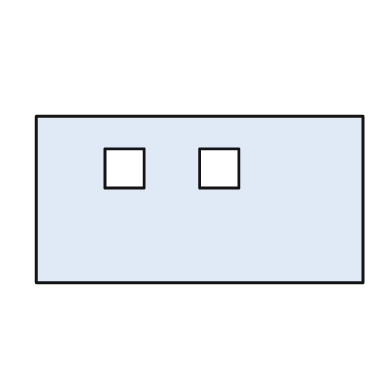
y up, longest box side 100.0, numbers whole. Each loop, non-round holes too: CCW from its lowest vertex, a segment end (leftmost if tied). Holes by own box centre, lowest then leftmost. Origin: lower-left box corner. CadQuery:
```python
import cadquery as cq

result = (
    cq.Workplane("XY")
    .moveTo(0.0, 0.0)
    .lineTo(100.0, 0.0)
    .lineTo(100.0, 51.0)
    .lineTo(0.0, 51.0)
    .close()
    .moveTo(21.0, 29.0)
    .lineTo(33.0, 29.0)
    .lineTo(33.0, 41.0)
    .lineTo(21.0, 41.0)
    .close()
    .moveTo(50.0, 29.0)
    .lineTo(62.0, 29.0)
    .lineTo(62.0, 41.0)
    .lineTo(50.0, 41.0)
    .close()
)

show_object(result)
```